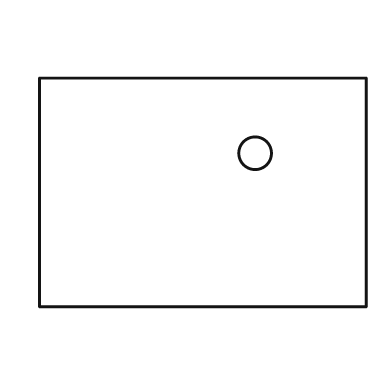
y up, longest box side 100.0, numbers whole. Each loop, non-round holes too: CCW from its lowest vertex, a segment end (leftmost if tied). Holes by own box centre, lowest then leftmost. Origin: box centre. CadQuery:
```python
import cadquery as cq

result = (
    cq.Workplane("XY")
    .moveTo(-50.0, -35.0)
    .lineTo(50.0, -35.0)
    .lineTo(50.0, 35.0)
    .lineTo(-50.0, 35.0)
    .close()
    .moveTo(16.0, 12.0)
    .circle(5.0)
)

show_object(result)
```